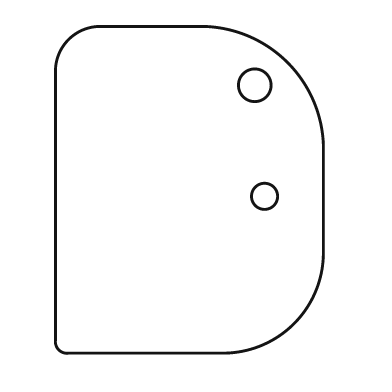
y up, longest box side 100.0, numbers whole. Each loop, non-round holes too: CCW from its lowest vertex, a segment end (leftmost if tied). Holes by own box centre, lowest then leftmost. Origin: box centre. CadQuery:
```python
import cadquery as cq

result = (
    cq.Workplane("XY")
    .moveTo(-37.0, -50.0)
    .lineTo(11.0, -50.0)
    .threePointArc((32.0, -41.0), (41.0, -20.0))
    .lineTo(41.0, 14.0)
    .threePointArc((30.0, 39.0), (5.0, 50.0))
    .lineTo(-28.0, 50.0)
    .threePointArc((-37.0, 46.0), (-41.0, 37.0))
    .lineTo(-41.0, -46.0)
    .threePointArc((-40.0, -49.0), (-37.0, -50.0))
    .close()
    .moveTo(23.0, -2.0)
    .circle(4.0)
    .moveTo(20.0, 32.0)
    .circle(5.0)
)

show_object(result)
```